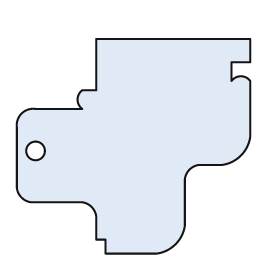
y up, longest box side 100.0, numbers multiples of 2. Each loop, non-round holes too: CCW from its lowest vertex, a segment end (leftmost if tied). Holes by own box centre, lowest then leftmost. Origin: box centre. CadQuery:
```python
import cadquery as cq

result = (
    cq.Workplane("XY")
    .moveTo(-12.0, -46.0)
    .lineTo(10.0, -46.0)
    .threePointArc((18.0, -42.0), (22.0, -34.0))
    .lineTo(22.0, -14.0)
    .threePointArc((24.0, -10.0), (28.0, -8.0))
    .lineTo(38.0, -8.0)
    .threePointArc((46.0, -4.0), (50.0, 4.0))
    .lineTo(50.0, 28.0)
    .threePointArc((46.0, 30.0), (42.0, 28.0))
    .lineTo(42.0, 36.0)
    .lineTo(50.0, 36.0)
    .lineTo(50.0, 46.0)
    .lineTo(-16.0, 46.0)
    .lineTo(-16.0, 24.0)
    .lineTo(-22.0, 24.0)
    .threePointArc((-24.0, 20.0), (-22.0, 16.0))
    .lineTo(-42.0, 16.0)
    .threePointArc((-48.0, 14.0), (-50.0, 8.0))
    .lineTo(-50.0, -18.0)
    .threePointArc((-48.0, -22.0), (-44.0, -24.0))
    .lineTo(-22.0, -24.0)
    .threePointArc((-18.0, -26.0), (-16.0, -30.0))
    .lineTo(-16.0, -40.0)
    .lineTo(-12.0, -40.0)
    .close()
    .moveTo(-42.0, -2.0)
    .circle(4.0)
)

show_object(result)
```